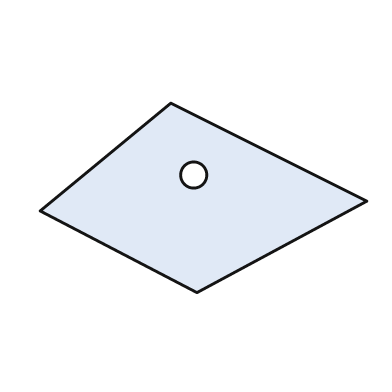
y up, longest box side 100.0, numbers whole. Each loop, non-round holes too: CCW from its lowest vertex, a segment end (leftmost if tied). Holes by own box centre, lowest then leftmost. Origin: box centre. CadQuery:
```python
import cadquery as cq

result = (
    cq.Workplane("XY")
    .moveTo(-2.0, -29.0)
    .lineTo(50.0, -1.0)
    .lineTo(-10.0, 29.0)
    .lineTo(-50.0, -4.0)
    .close()
    .moveTo(-3.0, 7.0)
    .circle(4.0)
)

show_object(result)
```